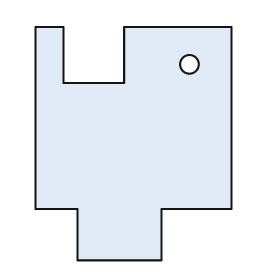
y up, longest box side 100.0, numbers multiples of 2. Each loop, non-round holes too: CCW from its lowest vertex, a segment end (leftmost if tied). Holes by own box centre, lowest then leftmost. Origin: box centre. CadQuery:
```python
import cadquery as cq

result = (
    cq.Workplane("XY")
    .moveTo(-24.0, -50.0)
    .lineTo(12.0, -50.0)
    .lineTo(12.0, -28.0)
    .lineTo(42.0, -28.0)
    .lineTo(42.0, 50.0)
    .lineTo(-4.0, 50.0)
    .lineTo(-4.0, 26.0)
    .lineTo(-30.0, 26.0)
    .lineTo(-30.0, 50.0)
    .lineTo(-42.0, 50.0)
    .lineTo(-42.0, -28.0)
    .lineTo(-24.0, -28.0)
    .close()
    .moveTo(24.0, 34.0)
    .circle(4.0)
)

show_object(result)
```